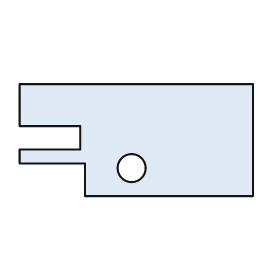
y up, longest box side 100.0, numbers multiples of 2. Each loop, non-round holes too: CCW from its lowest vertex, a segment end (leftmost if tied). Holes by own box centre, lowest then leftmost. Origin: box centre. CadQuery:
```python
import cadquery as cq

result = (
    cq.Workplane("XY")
    .moveTo(-22.0, -24.0)
    .lineTo(50.0, -24.0)
    .lineTo(50.0, 24.0)
    .lineTo(-50.0, 24.0)
    .lineTo(-50.0, 6.0)
    .lineTo(-24.0, 6.0)
    .lineTo(-24.0, -4.0)
    .lineTo(-50.0, -4.0)
    .lineTo(-50.0, -10.0)
    .lineTo(-22.0, -10.0)
    .close()
    .moveTo(-2.0, -12.0)
    .circle(6.0)
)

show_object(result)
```